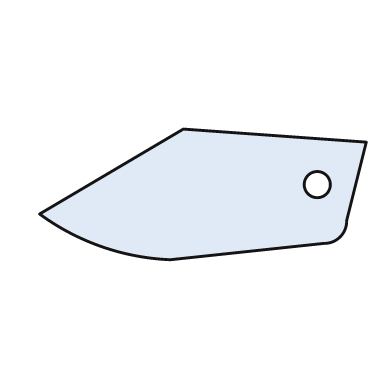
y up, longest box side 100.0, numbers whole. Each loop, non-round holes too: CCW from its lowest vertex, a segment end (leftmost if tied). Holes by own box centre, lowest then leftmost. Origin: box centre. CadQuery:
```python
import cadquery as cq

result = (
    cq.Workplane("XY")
    .moveTo(-10.0, -20.0)
    .lineTo(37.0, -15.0)
    .threePointArc((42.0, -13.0), (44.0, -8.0))
    .lineTo(50.0, 16.0)
    .lineTo(-6.0, 20.0)
    .lineTo(-50.0, -6.0)
    .threePointArc((-31.0, -16.0), (-10.0, -20.0))
    .close()
    .moveTo(35.0, 3.0)
    .circle(4.0)
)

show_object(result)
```